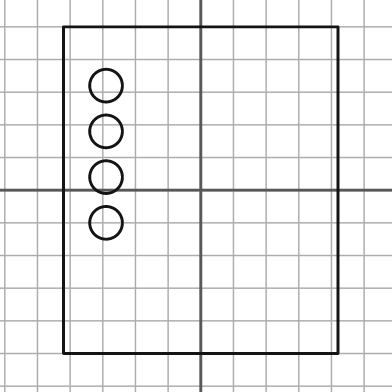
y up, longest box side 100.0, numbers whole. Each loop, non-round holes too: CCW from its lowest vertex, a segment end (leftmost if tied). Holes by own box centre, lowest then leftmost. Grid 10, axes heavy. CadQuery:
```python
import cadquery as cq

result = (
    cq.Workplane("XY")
    .moveTo(-42.0, -50.0)
    .lineTo(42.0, -50.0)
    .lineTo(42.0, 50.0)
    .lineTo(-42.0, 50.0)
    .close()
    .moveTo(-29.0, -10.0)
    .circle(5.0)
    .moveTo(-29.0, 4.0)
    .circle(5.0)
    .moveTo(-29.0, 18.0)
    .circle(5.0)
    .moveTo(-29.0, 32.0)
    .circle(5.0)
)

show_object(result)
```